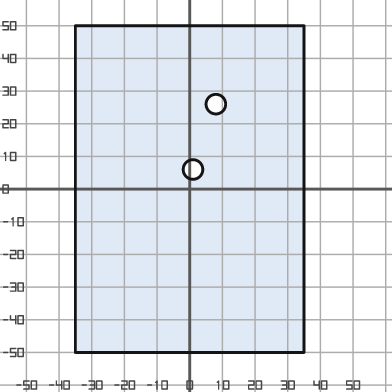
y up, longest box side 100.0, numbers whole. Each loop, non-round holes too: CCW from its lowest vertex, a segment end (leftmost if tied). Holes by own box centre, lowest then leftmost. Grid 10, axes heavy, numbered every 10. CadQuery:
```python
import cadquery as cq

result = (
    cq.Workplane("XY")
    .moveTo(-35.0, -50.0)
    .lineTo(35.0, -50.0)
    .lineTo(35.0, 50.0)
    .lineTo(-35.0, 50.0)
    .close()
    .moveTo(1.0, 6.0)
    .circle(3.0)
    .moveTo(8.0, 26.0)
    .circle(3.0)
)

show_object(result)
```